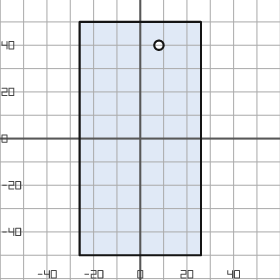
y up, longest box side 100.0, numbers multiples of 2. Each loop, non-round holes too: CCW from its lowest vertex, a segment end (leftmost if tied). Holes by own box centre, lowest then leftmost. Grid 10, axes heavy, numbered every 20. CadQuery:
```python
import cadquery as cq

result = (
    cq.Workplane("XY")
    .moveTo(-26.0, -50.0)
    .lineTo(26.0, -50.0)
    .lineTo(26.0, 50.0)
    .lineTo(-26.0, 50.0)
    .close()
    .moveTo(8.0, 40.0)
    .circle(2.0)
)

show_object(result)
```